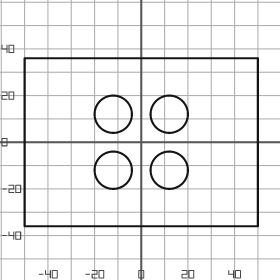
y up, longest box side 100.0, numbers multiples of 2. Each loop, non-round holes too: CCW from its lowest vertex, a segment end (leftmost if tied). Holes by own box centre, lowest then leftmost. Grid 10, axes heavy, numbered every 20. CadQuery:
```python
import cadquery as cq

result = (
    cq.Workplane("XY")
    .moveTo(-50.0, -36.0)
    .lineTo(50.0, -36.0)
    .lineTo(50.0, 36.0)
    .lineTo(-50.0, 36.0)
    .close()
    .moveTo(-12.0, -12.0)
    .circle(8.0)
    .moveTo(12.0, -12.0)
    .circle(8.0)
    .moveTo(-12.0, 12.0)
    .circle(8.0)
    .moveTo(12.0, 12.0)
    .circle(8.0)
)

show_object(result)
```